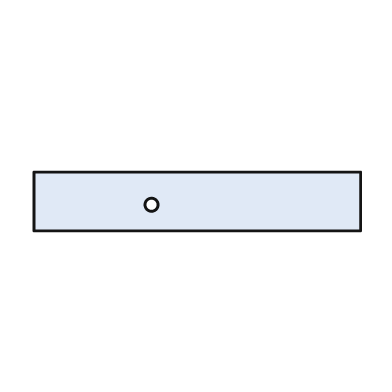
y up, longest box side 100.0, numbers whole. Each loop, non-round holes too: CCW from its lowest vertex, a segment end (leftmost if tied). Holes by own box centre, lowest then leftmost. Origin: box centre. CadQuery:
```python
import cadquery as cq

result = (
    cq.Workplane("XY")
    .moveTo(-50.0, -9.0)
    .lineTo(50.0, -9.0)
    .lineTo(50.0, 9.0)
    .lineTo(-50.0, 9.0)
    .close()
    .moveTo(-14.0, -1.0)
    .circle(2.0)
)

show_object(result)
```